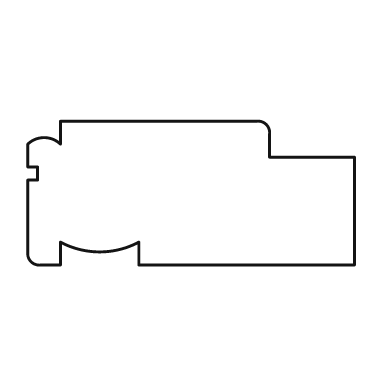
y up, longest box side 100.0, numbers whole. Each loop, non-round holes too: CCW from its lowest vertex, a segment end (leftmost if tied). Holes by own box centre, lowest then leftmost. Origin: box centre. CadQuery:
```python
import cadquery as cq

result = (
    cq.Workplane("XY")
    .moveTo(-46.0, -22.0)
    .lineTo(-40.0, -22.0)
    .lineTo(-40.0, -15.0)
    .threePointArc((-28.0, -18.0), (-16.0, -15.0))
    .lineTo(-16.0, -22.0)
    .lineTo(50.0, -22.0)
    .lineTo(50.0, 11.0)
    .lineTo(24.0, 11.0)
    .lineTo(24.0, 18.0)
    .threePointArc((23.0, 21.0), (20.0, 22.0))
    .lineTo(-40.0, 22.0)
    .lineTo(-40.0, 15.0)
    .threePointArc((-45.0, 17.0), (-50.0, 15.0))
    .lineTo(-50.0, 8.0)
    .lineTo(-47.0, 8.0)
    .lineTo(-47.0, 4.0)
    .lineTo(-50.0, 4.0)
    .lineTo(-50.0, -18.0)
    .threePointArc((-49.0, -21.0), (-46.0, -22.0))
    .close()
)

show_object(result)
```